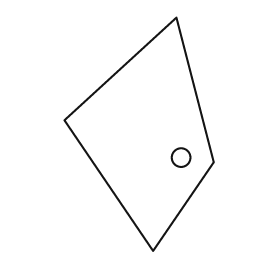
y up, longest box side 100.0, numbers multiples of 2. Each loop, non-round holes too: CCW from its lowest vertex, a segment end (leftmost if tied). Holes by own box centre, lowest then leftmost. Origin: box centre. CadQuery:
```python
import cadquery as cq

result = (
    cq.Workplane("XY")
    .moveTo(6.0, -50.0)
    .lineTo(32.0, -12.0)
    .lineTo(16.0, 50.0)
    .lineTo(-32.0, 6.0)
    .close()
    .moveTo(18.0, -10.0)
    .circle(4.0)
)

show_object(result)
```